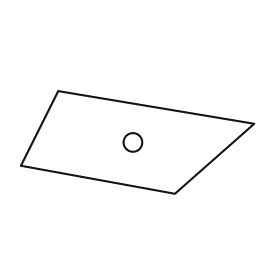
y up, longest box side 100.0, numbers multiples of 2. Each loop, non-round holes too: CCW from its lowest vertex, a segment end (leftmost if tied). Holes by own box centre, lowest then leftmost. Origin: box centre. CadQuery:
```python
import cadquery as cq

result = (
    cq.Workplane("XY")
    .moveTo(16.0, -22.0)
    .lineTo(50.0, 8.0)
    .lineTo(-34.0, 22.0)
    .lineTo(-50.0, -10.0)
    .close()
    .moveTo(-2.0, 0.0)
    .circle(4.0)
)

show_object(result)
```